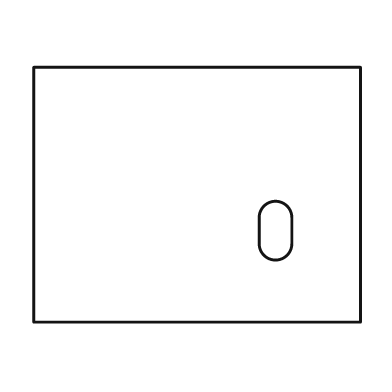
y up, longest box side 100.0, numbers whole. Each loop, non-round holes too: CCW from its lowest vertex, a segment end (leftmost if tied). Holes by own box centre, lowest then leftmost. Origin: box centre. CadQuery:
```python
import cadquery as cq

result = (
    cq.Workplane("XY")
    .moveTo(-50.0, -39.0)
    .lineTo(50.0, -39.0)
    .lineTo(50.0, 39.0)
    .lineTo(-50.0, 39.0)
    .close()
    .moveTo(19.0, -15.0)
    .threePointArc((24.0, -20.0), (29.0, -15.0))
    .lineTo(29.0, -7.0)
    .threePointArc((24.0, -2.0), (19.0, -7.0))
    .close()
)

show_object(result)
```